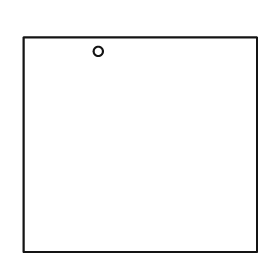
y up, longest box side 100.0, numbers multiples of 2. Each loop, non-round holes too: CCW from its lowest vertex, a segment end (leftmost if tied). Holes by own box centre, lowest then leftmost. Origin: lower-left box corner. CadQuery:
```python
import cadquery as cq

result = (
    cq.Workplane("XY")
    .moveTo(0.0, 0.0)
    .lineTo(100.0, 0.0)
    .lineTo(100.0, 92.0)
    .lineTo(0.0, 92.0)
    .close()
    .moveTo(32.0, 86.0)
    .circle(2.0)
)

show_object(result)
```